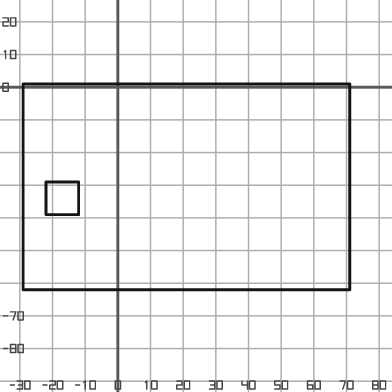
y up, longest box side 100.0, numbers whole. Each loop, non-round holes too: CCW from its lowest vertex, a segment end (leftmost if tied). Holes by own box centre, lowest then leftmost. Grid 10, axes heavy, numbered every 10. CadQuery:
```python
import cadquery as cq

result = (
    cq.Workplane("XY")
    .moveTo(-29.0, -62.0)
    .lineTo(71.0, -62.0)
    .lineTo(71.0, 1.0)
    .lineTo(-29.0, 1.0)
    .close()
    .moveTo(-22.0, -39.0)
    .lineTo(-12.0, -39.0)
    .lineTo(-12.0, -29.0)
    .lineTo(-22.0, -29.0)
    .close()
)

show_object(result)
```